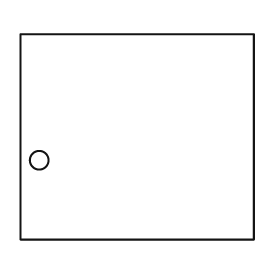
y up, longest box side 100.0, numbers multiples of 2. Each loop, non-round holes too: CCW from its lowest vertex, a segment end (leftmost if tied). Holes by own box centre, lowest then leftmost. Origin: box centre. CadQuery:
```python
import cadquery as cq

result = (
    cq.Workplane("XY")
    .moveTo(-50.0, -44.0)
    .lineTo(50.0, -44.0)
    .lineTo(50.0, 44.0)
    .lineTo(-50.0, 44.0)
    .close()
    .moveTo(-42.0, -10.0)
    .circle(4.0)
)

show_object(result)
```